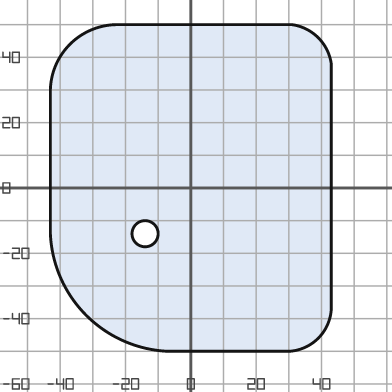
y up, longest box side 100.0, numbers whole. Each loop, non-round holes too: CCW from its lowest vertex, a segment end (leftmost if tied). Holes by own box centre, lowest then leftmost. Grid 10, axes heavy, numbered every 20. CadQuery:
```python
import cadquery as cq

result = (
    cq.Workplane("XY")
    .moveTo(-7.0, -50.0)
    .lineTo(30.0, -50.0)
    .threePointArc((39.0, -46.0), (43.0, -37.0))
    .lineTo(43.0, 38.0)
    .threePointArc((39.0, 46.0), (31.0, 50.0))
    .lineTo(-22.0, 50.0)
    .threePointArc((-37.0, 44.0), (-43.0, 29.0))
    .lineTo(-43.0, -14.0)
    .threePointArc((-32.0, -39.0), (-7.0, -50.0))
    .close()
    .moveTo(-14.0, -14.0)
    .circle(4.0)
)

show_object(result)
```